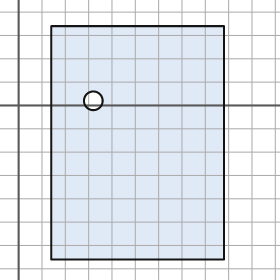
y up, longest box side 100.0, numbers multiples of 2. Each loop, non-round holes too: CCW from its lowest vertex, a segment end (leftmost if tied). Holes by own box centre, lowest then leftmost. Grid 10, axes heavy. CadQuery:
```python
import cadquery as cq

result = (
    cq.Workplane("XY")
    .moveTo(14.0, -66.0)
    .lineTo(88.0, -66.0)
    .lineTo(88.0, 34.0)
    .lineTo(14.0, 34.0)
    .close()
    .moveTo(32.0, 2.0)
    .circle(4.0)
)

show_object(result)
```